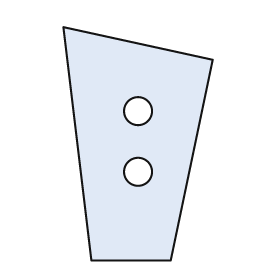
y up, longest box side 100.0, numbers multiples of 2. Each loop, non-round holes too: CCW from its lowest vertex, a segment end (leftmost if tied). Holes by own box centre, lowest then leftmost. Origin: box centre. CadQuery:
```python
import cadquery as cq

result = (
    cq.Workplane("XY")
    .moveTo(-20.0, -50.0)
    .lineTo(14.0, -50.0)
    .lineTo(32.0, 36.0)
    .lineTo(-32.0, 50.0)
    .close()
    .moveTo(0.0, -12.0)
    .circle(6.0)
    .moveTo(0.0, 14.0)
    .circle(6.0)
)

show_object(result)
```